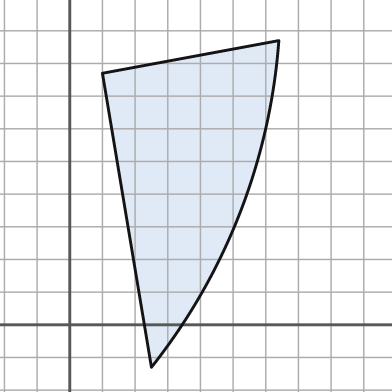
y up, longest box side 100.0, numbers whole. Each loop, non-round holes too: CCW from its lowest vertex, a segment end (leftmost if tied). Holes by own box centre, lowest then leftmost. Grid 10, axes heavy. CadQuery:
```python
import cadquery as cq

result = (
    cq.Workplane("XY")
    .moveTo(25.0, -13.0)
    .threePointArc((52.0, 34.0), (64.0, 87.0))
    .lineTo(10.0, 77.0)
    .close()
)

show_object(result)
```